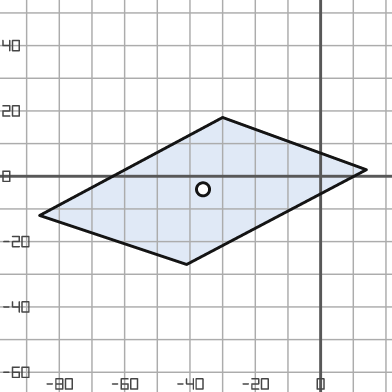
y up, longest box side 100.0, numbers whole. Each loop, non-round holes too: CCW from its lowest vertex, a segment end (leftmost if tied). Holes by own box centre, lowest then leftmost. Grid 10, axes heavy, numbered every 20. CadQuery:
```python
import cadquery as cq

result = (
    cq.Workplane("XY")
    .moveTo(-41.0, -27.0)
    .lineTo(14.0, 2.0)
    .lineTo(-30.0, 18.0)
    .lineTo(-86.0, -12.0)
    .close()
    .moveTo(-36.0, -4.0)
    .circle(2.0)
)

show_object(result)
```